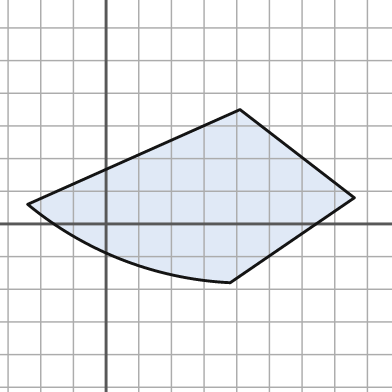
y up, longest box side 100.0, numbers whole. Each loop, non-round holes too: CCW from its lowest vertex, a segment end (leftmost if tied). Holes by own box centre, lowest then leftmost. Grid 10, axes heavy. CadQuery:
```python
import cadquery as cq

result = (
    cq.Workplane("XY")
    .moveTo(38.0, -18.0)
    .lineTo(76.0, 8.0)
    .lineTo(41.0, 35.0)
    .lineTo(-24.0, 6.0)
    .threePointArc((5.0, -11.0), (38.0, -18.0))
    .close()
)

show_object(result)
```